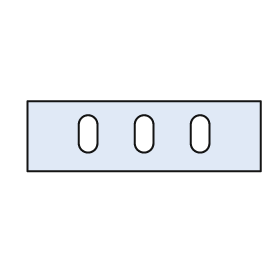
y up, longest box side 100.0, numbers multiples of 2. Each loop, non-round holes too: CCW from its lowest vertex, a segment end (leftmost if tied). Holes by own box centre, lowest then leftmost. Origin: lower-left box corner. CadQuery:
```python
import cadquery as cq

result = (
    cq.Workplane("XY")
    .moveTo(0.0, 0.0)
    .lineTo(100.0, 0.0)
    .lineTo(100.0, 30.0)
    .lineTo(0.0, 30.0)
    .close()
    .moveTo(22.0, 12.0)
    .threePointArc((26.0, 8.0), (30.0, 12.0))
    .lineTo(30.0, 20.0)
    .threePointArc((26.0, 24.0), (22.0, 20.0))
    .close()
    .moveTo(46.0, 12.0)
    .threePointArc((50.0, 8.0), (54.0, 12.0))
    .lineTo(54.0, 20.0)
    .threePointArc((50.0, 24.0), (46.0, 20.0))
    .close()
    .moveTo(70.0, 12.0)
    .threePointArc((74.0, 8.0), (78.0, 12.0))
    .lineTo(78.0, 20.0)
    .threePointArc((74.0, 24.0), (70.0, 20.0))
    .close()
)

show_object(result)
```